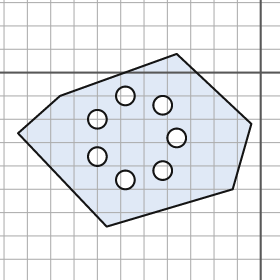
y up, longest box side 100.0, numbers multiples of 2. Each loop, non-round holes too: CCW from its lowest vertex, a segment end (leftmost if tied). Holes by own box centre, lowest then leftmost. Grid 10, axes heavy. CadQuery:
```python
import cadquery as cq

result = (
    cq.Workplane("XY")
    .moveTo(-66.0, -66.0)
    .lineTo(-12.0, -50.0)
    .lineTo(-4.0, -22.0)
    .lineTo(-36.0, 8.0)
    .lineTo(-86.0, -10.0)
    .lineTo(-104.0, -26.0)
    .close()
    .moveTo(-58.0, -46.0)
    .circle(4.0)
    .moveTo(-42.0, -42.0)
    .circle(4.0)
    .moveTo(-70.0, -36.0)
    .circle(4.0)
    .moveTo(-36.0, -28.0)
    .circle(4.0)
    .moveTo(-70.0, -20.0)
    .circle(4.0)
    .moveTo(-42.0, -14.0)
    .circle(4.0)
    .moveTo(-58.0, -10.0)
    .circle(4.0)
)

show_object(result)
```